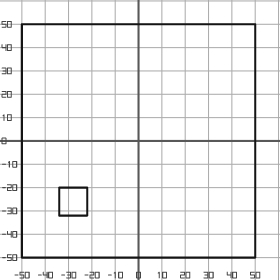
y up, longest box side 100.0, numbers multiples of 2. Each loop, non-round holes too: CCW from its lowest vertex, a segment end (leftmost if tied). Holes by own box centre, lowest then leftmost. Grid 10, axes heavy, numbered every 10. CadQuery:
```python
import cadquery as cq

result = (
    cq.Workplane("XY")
    .moveTo(-50.0, -50.0)
    .lineTo(50.0, -50.0)
    .lineTo(50.0, 50.0)
    .lineTo(-50.0, 50.0)
    .close()
    .moveTo(-34.0, -32.0)
    .lineTo(-22.0, -32.0)
    .lineTo(-22.0, -20.0)
    .lineTo(-34.0, -20.0)
    .close()
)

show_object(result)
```